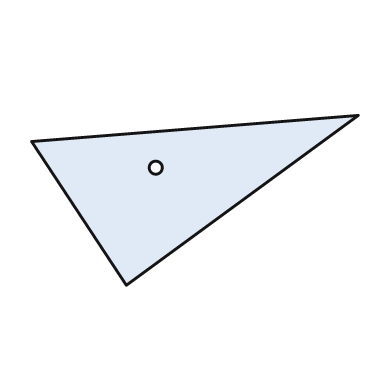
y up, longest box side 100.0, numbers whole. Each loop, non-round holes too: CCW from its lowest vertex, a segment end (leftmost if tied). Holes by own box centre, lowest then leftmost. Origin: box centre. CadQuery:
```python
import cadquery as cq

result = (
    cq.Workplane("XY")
    .moveTo(-21.0, -26.0)
    .lineTo(50.0, 26.0)
    .lineTo(-50.0, 18.0)
    .close()
    .moveTo(-12.0, 10.0)
    .circle(2.0)
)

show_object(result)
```